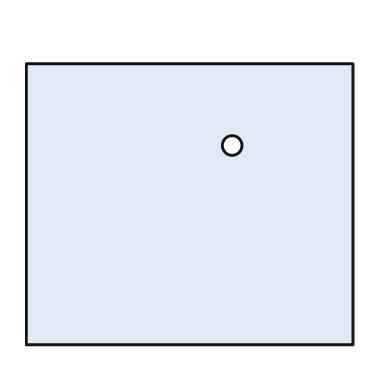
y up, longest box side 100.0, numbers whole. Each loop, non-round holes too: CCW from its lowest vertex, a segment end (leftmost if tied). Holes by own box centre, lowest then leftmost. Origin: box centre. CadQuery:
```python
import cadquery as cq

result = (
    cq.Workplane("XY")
    .moveTo(-50.0, -43.0)
    .lineTo(50.0, -43.0)
    .lineTo(50.0, 43.0)
    .lineTo(-50.0, 43.0)
    .close()
    .moveTo(13.0, 18.0)
    .circle(3.0)
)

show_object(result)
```